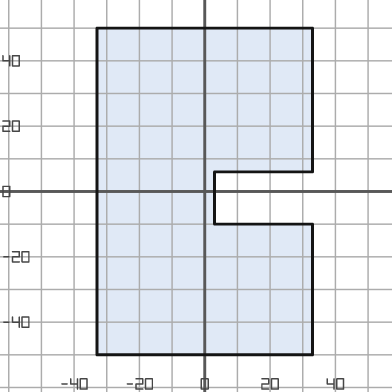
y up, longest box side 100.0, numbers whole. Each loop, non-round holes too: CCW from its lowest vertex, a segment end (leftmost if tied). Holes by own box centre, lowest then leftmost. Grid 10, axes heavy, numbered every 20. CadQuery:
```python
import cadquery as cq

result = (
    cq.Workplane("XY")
    .moveTo(-33.0, -50.0)
    .lineTo(33.0, -50.0)
    .lineTo(33.0, -10.0)
    .lineTo(3.0, -10.0)
    .lineTo(3.0, 6.0)
    .lineTo(33.0, 6.0)
    .lineTo(33.0, 50.0)
    .lineTo(-33.0, 50.0)
    .close()
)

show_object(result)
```